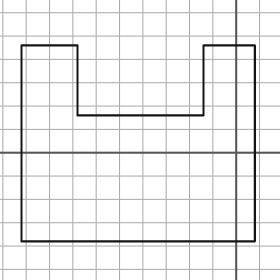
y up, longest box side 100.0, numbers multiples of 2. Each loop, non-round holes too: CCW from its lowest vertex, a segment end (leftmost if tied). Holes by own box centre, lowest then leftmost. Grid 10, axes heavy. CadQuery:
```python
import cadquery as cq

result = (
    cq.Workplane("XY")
    .moveTo(-92.0, -38.0)
    .lineTo(8.0, -38.0)
    .lineTo(8.0, 46.0)
    .lineTo(-14.0, 46.0)
    .lineTo(-14.0, 16.0)
    .lineTo(-68.0, 16.0)
    .lineTo(-68.0, 46.0)
    .lineTo(-92.0, 46.0)
    .close()
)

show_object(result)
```